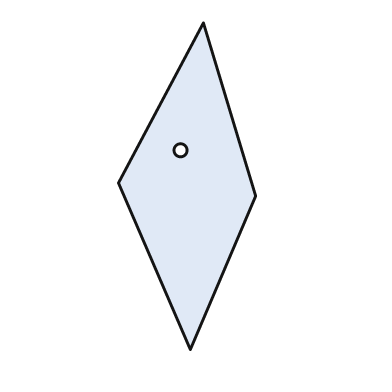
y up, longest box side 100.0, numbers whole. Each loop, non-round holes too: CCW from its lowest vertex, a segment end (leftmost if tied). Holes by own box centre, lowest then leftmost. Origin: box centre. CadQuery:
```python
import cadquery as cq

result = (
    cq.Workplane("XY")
    .moveTo(1.0, -50.0)
    .lineTo(21.0, -3.0)
    .lineTo(5.0, 50.0)
    .lineTo(-21.0, 1.0)
    .close()
    .moveTo(-2.0, 11.0)
    .circle(2.0)
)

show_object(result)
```